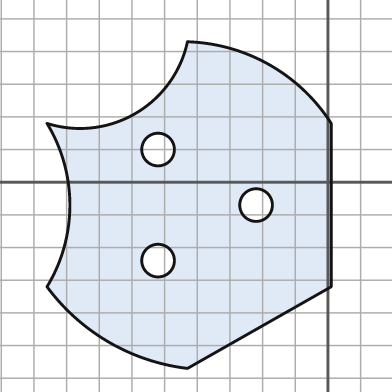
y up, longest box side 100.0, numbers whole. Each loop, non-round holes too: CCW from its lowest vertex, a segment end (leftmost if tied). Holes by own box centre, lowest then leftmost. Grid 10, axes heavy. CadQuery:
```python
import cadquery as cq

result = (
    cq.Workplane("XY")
    .moveTo(-43.0, -57.0)
    .lineTo(1.0, -32.0)
    .lineTo(1.0, 18.0)
    .threePointArc((-18.0, 36.0), (-43.0, 43.0))
    .threePointArc((-59.0, 21.0), (-86.0, 18.0))
    .threePointArc((-79.0, -7.0), (-86.0, -32.0))
    .threePointArc((-67.0, -49.0), (-43.0, -57.0))
    .close()
    .moveTo(-52.0, -24.0)
    .circle(5.0)
    .moveTo(-22.0, -7.0)
    .circle(5.0)
    .moveTo(-52.0, 10.0)
    .circle(5.0)
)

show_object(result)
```